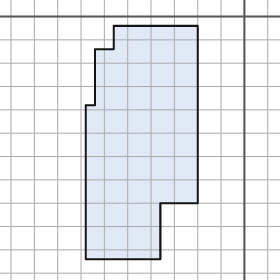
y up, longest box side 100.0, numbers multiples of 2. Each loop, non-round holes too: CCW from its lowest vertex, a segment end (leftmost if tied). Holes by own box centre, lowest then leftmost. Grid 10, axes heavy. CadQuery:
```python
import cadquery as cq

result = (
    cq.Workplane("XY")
    .moveTo(-68.0, -104.0)
    .lineTo(-36.0, -104.0)
    .lineTo(-36.0, -80.0)
    .lineTo(-20.0, -80.0)
    .lineTo(-20.0, -4.0)
    .lineTo(-56.0, -4.0)
    .lineTo(-56.0, -14.0)
    .lineTo(-64.0, -14.0)
    .lineTo(-64.0, -38.0)
    .lineTo(-68.0, -38.0)
    .close()
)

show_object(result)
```